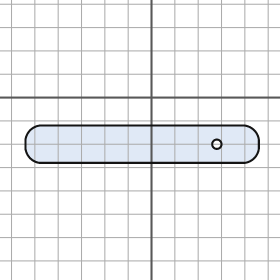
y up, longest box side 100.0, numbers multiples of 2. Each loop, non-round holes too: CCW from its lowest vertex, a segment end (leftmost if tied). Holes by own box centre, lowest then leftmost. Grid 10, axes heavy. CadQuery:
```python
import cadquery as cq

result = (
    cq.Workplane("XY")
    .moveTo(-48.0, -28.0)
    .lineTo(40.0, -28.0)
    .threePointArc((44.0, -26.0), (46.0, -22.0))
    .lineTo(46.0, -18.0)
    .threePointArc((44.0, -14.0), (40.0, -12.0))
    .lineTo(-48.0, -12.0)
    .threePointArc((-52.0, -14.0), (-54.0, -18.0))
    .lineTo(-54.0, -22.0)
    .threePointArc((-52.0, -26.0), (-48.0, -28.0))
    .close()
    .moveTo(28.0, -20.0)
    .circle(2.0)
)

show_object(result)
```